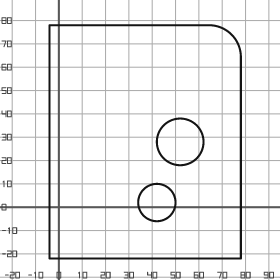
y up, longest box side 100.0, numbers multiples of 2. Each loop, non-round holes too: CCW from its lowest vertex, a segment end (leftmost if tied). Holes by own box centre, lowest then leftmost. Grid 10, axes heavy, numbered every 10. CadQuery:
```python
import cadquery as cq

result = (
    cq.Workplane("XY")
    .moveTo(-4.0, -22.0)
    .lineTo(78.0, -22.0)
    .lineTo(78.0, 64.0)
    .threePointArc((74.0, 74.0), (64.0, 78.0))
    .lineTo(-4.0, 78.0)
    .close()
    .moveTo(42.0, 2.0)
    .circle(8.0)
    .moveTo(52.0, 28.0)
    .circle(10.0)
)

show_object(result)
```